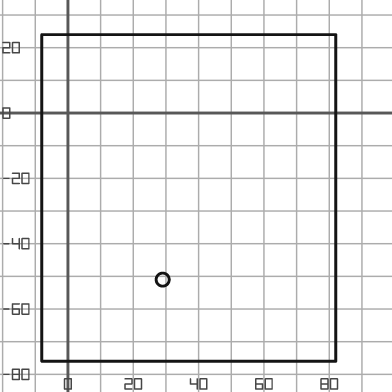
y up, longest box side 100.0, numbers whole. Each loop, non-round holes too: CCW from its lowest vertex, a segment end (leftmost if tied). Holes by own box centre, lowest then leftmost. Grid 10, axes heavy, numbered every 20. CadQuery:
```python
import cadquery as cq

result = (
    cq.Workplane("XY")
    .moveTo(-8.0, -76.0)
    .lineTo(82.0, -76.0)
    .lineTo(82.0, 24.0)
    .lineTo(-8.0, 24.0)
    .close()
    .moveTo(29.0, -51.0)
    .circle(2.0)
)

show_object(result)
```